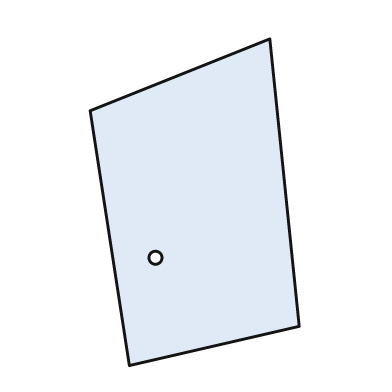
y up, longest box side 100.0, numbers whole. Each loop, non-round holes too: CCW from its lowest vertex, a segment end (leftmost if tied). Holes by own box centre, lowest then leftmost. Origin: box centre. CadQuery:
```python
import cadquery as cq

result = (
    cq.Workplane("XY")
    .moveTo(-20.0, -50.0)
    .lineTo(32.0, -38.0)
    .lineTo(23.0, 50.0)
    .lineTo(-32.0, 28.0)
    .close()
    .moveTo(-12.0, -17.0)
    .circle(2.0)
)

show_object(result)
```